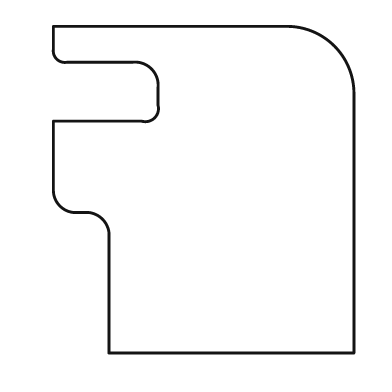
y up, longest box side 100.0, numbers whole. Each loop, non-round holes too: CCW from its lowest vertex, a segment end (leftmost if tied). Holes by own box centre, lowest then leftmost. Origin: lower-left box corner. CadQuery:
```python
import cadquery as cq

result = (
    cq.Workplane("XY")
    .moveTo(17.0, 0.0)
    .lineTo(92.0, 0.0)
    .lineTo(92.0, 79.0)
    .threePointArc((86.0, 94.0), (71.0, 100.0))
    .lineTo(0.0, 100.0)
    .lineTo(0.0, 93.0)
    .threePointArc((1.0, 90.0), (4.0, 89.0))
    .lineTo(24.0, 89.0)
    .threePointArc((30.0, 87.0), (32.0, 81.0))
    .lineTo(32.0, 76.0)
    .threePointArc((31.0, 72.0), (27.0, 71.0))
    .lineTo(0.0, 71.0)
    .lineTo(0.0, 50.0)
    .threePointArc((2.0, 45.0), (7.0, 43.0))
    .lineTo(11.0, 43.0)
    .threePointArc((15.0, 41.0), (17.0, 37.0))
    .close()
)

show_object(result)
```